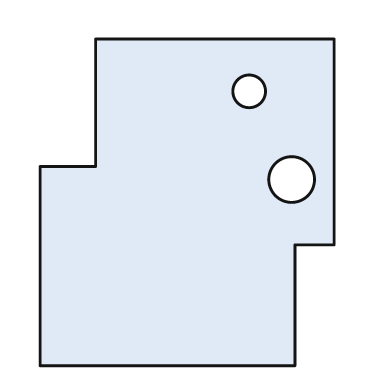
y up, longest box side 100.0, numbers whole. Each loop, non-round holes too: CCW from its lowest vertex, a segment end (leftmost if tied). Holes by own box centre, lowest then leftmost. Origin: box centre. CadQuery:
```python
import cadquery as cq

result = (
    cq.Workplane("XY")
    .moveTo(-45.0, -50.0)
    .lineTo(33.0, -50.0)
    .lineTo(33.0, -13.0)
    .lineTo(45.0, -13.0)
    .lineTo(45.0, 50.0)
    .lineTo(-28.0, 50.0)
    .lineTo(-28.0, 11.0)
    .lineTo(-45.0, 11.0)
    .close()
    .moveTo(32.0, 7.0)
    .circle(7.0)
    .moveTo(19.0, 34.0)
    .circle(5.0)
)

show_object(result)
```